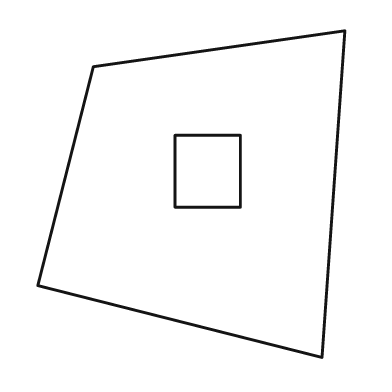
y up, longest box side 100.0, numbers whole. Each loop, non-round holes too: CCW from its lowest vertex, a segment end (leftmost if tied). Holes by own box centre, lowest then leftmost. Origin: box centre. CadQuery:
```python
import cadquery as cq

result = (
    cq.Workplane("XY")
    .moveTo(40.0, -50.0)
    .lineTo(47.0, 50.0)
    .lineTo(-30.0, 39.0)
    .lineTo(-47.0, -28.0)
    .close()
    .moveTo(-5.0, -4.0)
    .lineTo(15.0, -4.0)
    .lineTo(15.0, 18.0)
    .lineTo(-5.0, 18.0)
    .close()
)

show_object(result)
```